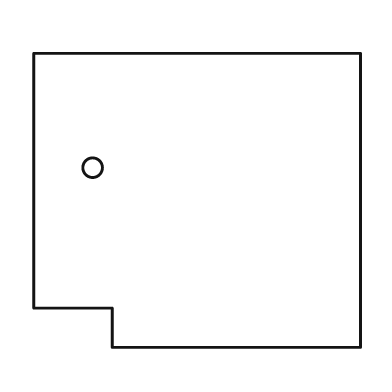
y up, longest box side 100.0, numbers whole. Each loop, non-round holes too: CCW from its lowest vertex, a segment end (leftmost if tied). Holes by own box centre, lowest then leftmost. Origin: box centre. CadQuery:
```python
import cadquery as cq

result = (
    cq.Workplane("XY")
    .moveTo(-26.0, -45.0)
    .lineTo(50.0, -45.0)
    .lineTo(50.0, 45.0)
    .lineTo(-50.0, 45.0)
    .lineTo(-50.0, -33.0)
    .lineTo(-26.0, -33.0)
    .close()
    .moveTo(-32.0, 10.0)
    .circle(3.0)
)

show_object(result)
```